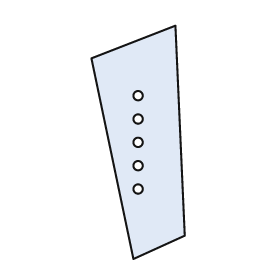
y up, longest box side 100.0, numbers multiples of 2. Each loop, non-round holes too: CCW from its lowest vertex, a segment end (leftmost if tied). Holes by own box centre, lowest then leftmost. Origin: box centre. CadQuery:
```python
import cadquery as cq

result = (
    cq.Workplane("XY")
    .moveTo(-2.0, -50.0)
    .lineTo(20.0, -40.0)
    .lineTo(16.0, 50.0)
    .lineTo(-20.0, 36.0)
    .close()
    .moveTo(0.0, -20.0)
    .circle(2.0)
    .moveTo(0.0, -10.0)
    .circle(2.0)
    .moveTo(0.0, 0.0)
    .circle(2.0)
    .moveTo(0.0, 10.0)
    .circle(2.0)
    .moveTo(0.0, 20.0)
    .circle(2.0)
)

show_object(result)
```